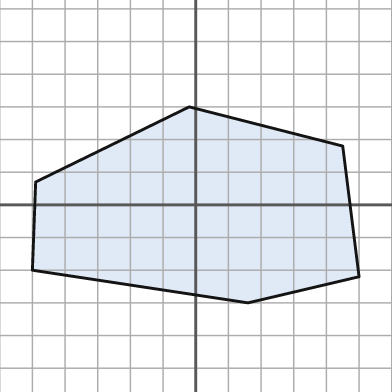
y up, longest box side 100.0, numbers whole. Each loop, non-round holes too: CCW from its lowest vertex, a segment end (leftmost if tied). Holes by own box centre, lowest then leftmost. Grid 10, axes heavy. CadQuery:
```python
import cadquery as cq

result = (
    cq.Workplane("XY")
    .moveTo(16.0, -30.0)
    .lineTo(50.0, -22.0)
    .lineTo(45.0, 18.0)
    .lineTo(-2.0, 30.0)
    .lineTo(-49.0, 7.0)
    .lineTo(-50.0, -20.0)
    .close()
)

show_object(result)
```